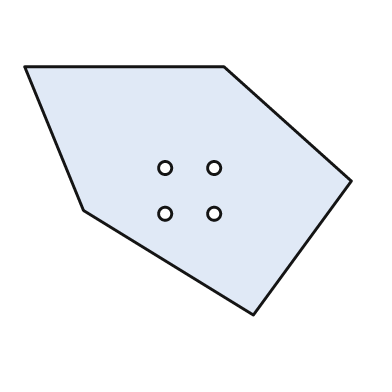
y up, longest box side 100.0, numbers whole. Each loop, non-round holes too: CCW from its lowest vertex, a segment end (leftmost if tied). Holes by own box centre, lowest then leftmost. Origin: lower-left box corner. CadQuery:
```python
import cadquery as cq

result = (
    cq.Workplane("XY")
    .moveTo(70.0, 0.0)
    .lineTo(100.0, 41.0)
    .lineTo(61.0, 76.0)
    .lineTo(0.0, 76.0)
    .lineTo(18.0, 32.0)
    .close()
    .moveTo(43.0, 31.0)
    .circle(2.0)
    .moveTo(58.0, 31.0)
    .circle(2.0)
    .moveTo(43.0, 45.0)
    .circle(2.0)
    .moveTo(58.0, 45.0)
    .circle(2.0)
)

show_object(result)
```